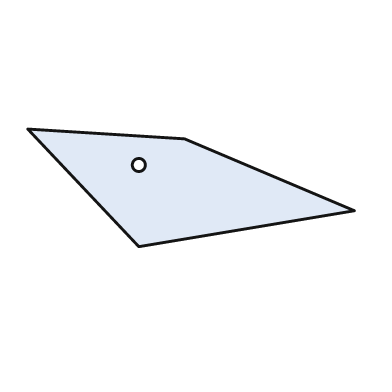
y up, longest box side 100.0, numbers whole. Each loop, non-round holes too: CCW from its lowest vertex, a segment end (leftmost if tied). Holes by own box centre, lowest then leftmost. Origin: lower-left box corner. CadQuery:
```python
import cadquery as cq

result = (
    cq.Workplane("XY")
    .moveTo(34.0, 0.0)
    .lineTo(100.0, 11.0)
    .lineTo(48.0, 33.0)
    .lineTo(0.0, 36.0)
    .close()
    .moveTo(34.0, 25.0)
    .circle(2.0)
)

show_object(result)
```